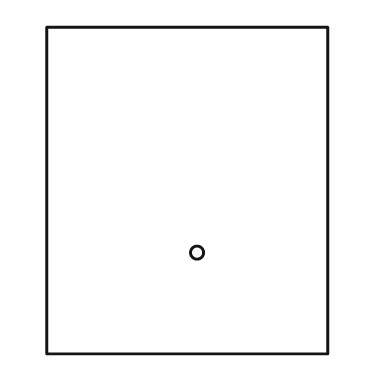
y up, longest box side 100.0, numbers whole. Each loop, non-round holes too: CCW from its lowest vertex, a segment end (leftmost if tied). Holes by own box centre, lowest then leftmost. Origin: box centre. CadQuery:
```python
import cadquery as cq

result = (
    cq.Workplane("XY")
    .moveTo(-43.0, -50.0)
    .lineTo(43.0, -50.0)
    .lineTo(43.0, 50.0)
    .lineTo(-43.0, 50.0)
    .close()
    .moveTo(3.0, -19.0)
    .circle(2.0)
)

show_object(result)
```